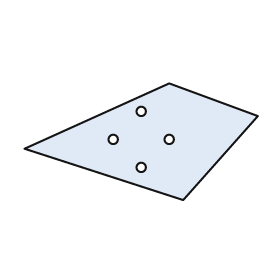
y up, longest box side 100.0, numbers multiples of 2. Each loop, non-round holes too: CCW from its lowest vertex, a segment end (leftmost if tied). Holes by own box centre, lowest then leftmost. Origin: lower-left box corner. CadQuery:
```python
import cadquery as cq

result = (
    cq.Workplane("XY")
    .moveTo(68.0, 0.0)
    .lineTo(100.0, 36.0)
    .lineTo(62.0, 50.0)
    .lineTo(0.0, 22.0)
    .close()
    .moveTo(50.0, 14.0)
    .circle(2.0)
    .moveTo(38.0, 26.0)
    .circle(2.0)
    .moveTo(62.0, 26.0)
    .circle(2.0)
    .moveTo(50.0, 38.0)
    .circle(2.0)
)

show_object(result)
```